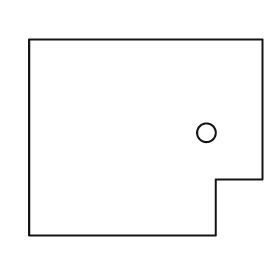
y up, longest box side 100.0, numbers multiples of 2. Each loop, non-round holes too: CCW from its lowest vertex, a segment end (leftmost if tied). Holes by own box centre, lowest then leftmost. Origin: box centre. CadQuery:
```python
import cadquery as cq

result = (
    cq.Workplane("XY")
    .moveTo(-50.0, -42.0)
    .lineTo(30.0, -42.0)
    .lineTo(30.0, -18.0)
    .lineTo(50.0, -18.0)
    .lineTo(50.0, 42.0)
    .lineTo(-50.0, 42.0)
    .close()
    .moveTo(26.0, 2.0)
    .circle(4.0)
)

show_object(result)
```